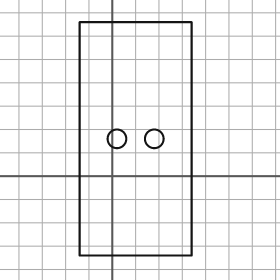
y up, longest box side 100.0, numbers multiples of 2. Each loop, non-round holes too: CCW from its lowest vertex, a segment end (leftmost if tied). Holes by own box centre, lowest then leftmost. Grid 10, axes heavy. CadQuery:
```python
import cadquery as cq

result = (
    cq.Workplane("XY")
    .moveTo(-14.0, -34.0)
    .lineTo(34.0, -34.0)
    .lineTo(34.0, 66.0)
    .lineTo(-14.0, 66.0)
    .close()
    .moveTo(2.0, 16.0)
    .circle(4.0)
    .moveTo(18.0, 16.0)
    .circle(4.0)
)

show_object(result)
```